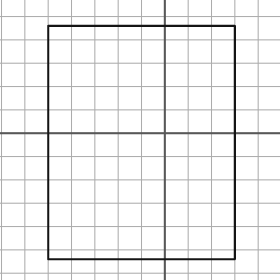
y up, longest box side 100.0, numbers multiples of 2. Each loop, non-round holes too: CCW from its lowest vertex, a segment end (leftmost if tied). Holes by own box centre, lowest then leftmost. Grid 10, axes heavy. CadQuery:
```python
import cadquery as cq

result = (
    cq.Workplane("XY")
    .moveTo(-50.0, -54.0)
    .lineTo(30.0, -54.0)
    .lineTo(30.0, 46.0)
    .lineTo(-50.0, 46.0)
    .close()
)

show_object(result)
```